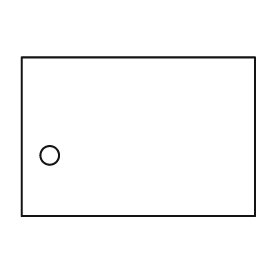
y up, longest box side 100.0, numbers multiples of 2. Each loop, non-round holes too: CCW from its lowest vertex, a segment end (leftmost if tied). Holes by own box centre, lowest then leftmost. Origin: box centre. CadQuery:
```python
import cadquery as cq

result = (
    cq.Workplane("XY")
    .moveTo(-50.0, -34.0)
    .lineTo(50.0, -34.0)
    .lineTo(50.0, 34.0)
    .lineTo(-50.0, 34.0)
    .close()
    .moveTo(-38.0, -8.0)
    .circle(4.0)
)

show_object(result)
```